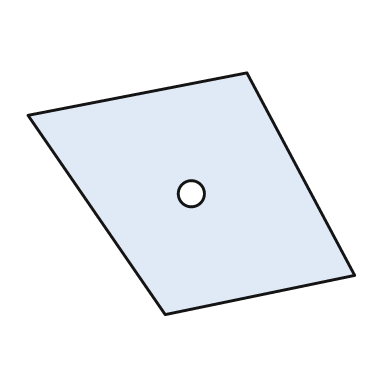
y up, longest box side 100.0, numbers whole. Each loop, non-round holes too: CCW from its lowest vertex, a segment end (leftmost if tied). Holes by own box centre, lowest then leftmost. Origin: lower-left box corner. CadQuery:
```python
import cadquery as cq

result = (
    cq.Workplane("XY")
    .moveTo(42.0, 0.0)
    .lineTo(100.0, 12.0)
    .lineTo(67.0, 74.0)
    .lineTo(0.0, 61.0)
    .close()
    .moveTo(50.0, 37.0)
    .circle(4.0)
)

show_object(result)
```